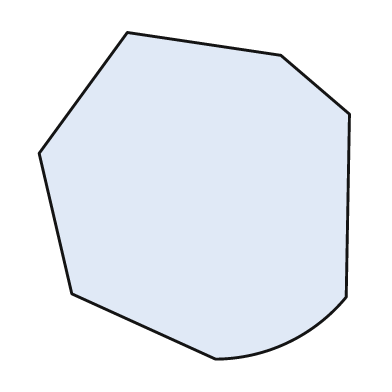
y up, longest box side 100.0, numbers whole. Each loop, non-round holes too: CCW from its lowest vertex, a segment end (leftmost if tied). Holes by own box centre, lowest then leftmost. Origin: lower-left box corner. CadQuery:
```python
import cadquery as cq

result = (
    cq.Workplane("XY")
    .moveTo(54.0, 0.0)
    .threePointArc((76.0, 5.0), (94.0, 19.0))
    .lineTo(95.0, 75.0)
    .lineTo(74.0, 93.0)
    .lineTo(27.0, 100.0)
    .lineTo(0.0, 63.0)
    .lineTo(10.0, 20.0)
    .close()
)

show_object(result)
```